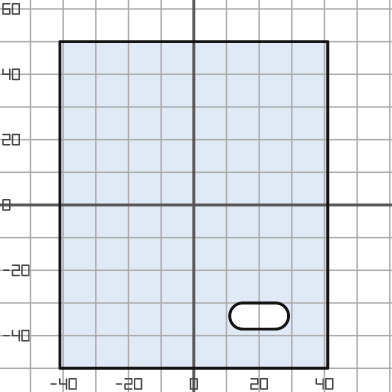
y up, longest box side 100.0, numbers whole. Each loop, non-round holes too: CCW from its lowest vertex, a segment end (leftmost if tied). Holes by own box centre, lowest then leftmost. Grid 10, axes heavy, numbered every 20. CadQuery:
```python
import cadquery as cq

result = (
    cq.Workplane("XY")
    .moveTo(-41.0, -50.0)
    .lineTo(41.0, -50.0)
    .lineTo(41.0, 50.0)
    .lineTo(-41.0, 50.0)
    .close()
    .moveTo(15.0, -38.0)
    .lineTo(25.0, -38.0)
    .threePointArc((29.0, -34.0), (25.0, -30.0))
    .lineTo(15.0, -30.0)
    .threePointArc((11.0, -34.0), (15.0, -38.0))
    .close()
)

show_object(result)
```